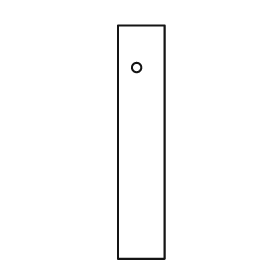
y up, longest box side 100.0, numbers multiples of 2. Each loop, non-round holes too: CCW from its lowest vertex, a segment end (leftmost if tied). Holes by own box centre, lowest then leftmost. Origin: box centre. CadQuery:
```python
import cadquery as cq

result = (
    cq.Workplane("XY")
    .moveTo(-10.0, -50.0)
    .lineTo(10.0, -50.0)
    .lineTo(10.0, 50.0)
    .lineTo(-10.0, 50.0)
    .close()
    .moveTo(-2.0, 32.0)
    .circle(2.0)
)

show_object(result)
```